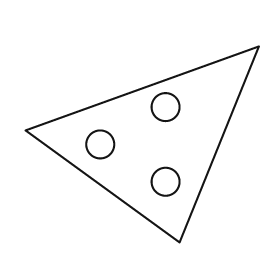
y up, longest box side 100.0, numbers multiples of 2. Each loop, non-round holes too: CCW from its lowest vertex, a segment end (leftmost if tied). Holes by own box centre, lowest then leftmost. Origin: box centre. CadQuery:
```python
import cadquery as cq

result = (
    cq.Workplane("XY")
    .moveTo(16.0, -42.0)
    .lineTo(50.0, 42.0)
    .lineTo(-50.0, 6.0)
    .close()
    .moveTo(10.0, -16.0)
    .circle(6.0)
    .moveTo(-18.0, 0.0)
    .circle(6.0)
    .moveTo(10.0, 16.0)
    .circle(6.0)
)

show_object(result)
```